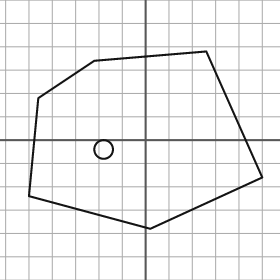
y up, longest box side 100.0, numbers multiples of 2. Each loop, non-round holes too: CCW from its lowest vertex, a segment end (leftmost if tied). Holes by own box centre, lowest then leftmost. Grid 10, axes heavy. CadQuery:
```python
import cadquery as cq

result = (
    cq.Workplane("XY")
    .moveTo(2.0, -38.0)
    .lineTo(50.0, -16.0)
    .lineTo(26.0, 38.0)
    .lineTo(-22.0, 34.0)
    .lineTo(-46.0, 18.0)
    .lineTo(-50.0, -24.0)
    .close()
    .moveTo(-18.0, -4.0)
    .circle(4.0)
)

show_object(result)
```